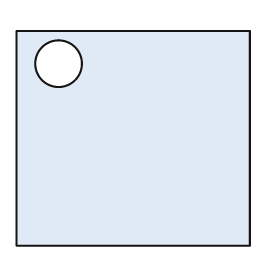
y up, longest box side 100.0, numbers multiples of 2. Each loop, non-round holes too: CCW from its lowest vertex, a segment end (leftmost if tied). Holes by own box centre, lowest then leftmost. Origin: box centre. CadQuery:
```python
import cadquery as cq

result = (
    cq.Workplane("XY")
    .moveTo(-50.0, -46.0)
    .lineTo(50.0, -46.0)
    .lineTo(50.0, 46.0)
    .lineTo(-50.0, 46.0)
    .close()
    .moveTo(-32.0, 32.0)
    .circle(10.0)
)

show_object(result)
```